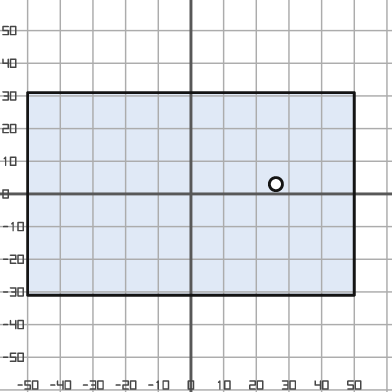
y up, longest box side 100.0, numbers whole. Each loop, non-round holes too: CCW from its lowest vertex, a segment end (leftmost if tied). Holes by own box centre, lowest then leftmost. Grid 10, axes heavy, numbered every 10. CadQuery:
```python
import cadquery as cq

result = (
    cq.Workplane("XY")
    .moveTo(-50.0, -31.0)
    .lineTo(50.0, -31.0)
    .lineTo(50.0, 31.0)
    .lineTo(-50.0, 31.0)
    .close()
    .moveTo(26.0, 3.0)
    .circle(2.0)
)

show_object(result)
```